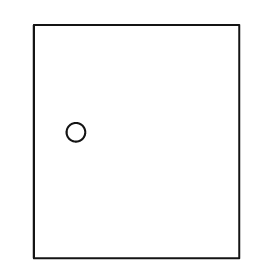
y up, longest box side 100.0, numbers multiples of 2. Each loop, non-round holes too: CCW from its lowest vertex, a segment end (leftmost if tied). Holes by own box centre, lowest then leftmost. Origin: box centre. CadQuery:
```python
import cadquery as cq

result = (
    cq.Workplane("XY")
    .moveTo(-44.0, -50.0)
    .lineTo(44.0, -50.0)
    .lineTo(44.0, 50.0)
    .lineTo(-44.0, 50.0)
    .close()
    .moveTo(-26.0, 4.0)
    .circle(4.0)
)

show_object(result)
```